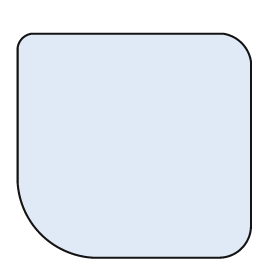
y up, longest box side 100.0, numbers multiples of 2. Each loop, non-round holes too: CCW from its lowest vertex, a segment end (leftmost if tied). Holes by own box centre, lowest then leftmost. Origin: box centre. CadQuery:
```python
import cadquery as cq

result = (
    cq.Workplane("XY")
    .moveTo(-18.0, -48.0)
    .lineTo(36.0, -48.0)
    .threePointArc((46.0, -44.0), (50.0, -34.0))
    .lineTo(50.0, 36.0)
    .threePointArc((46.0, 44.0), (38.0, 48.0))
    .lineTo(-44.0, 48.0)
    .threePointArc((-48.0, 46.0), (-50.0, 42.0))
    .lineTo(-50.0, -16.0)
    .threePointArc((-40.0, -38.0), (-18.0, -48.0))
    .close()
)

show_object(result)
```